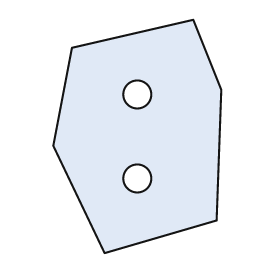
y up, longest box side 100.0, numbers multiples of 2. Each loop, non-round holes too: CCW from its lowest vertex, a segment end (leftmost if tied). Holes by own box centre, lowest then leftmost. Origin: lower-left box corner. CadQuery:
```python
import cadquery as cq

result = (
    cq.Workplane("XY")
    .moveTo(22.0, 0.0)
    .lineTo(70.0, 14.0)
    .lineTo(72.0, 70.0)
    .lineTo(60.0, 100.0)
    .lineTo(8.0, 88.0)
    .lineTo(0.0, 46.0)
    .close()
    .moveTo(36.0, 32.0)
    .circle(6.0)
    .moveTo(36.0, 68.0)
    .circle(6.0)
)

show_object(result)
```